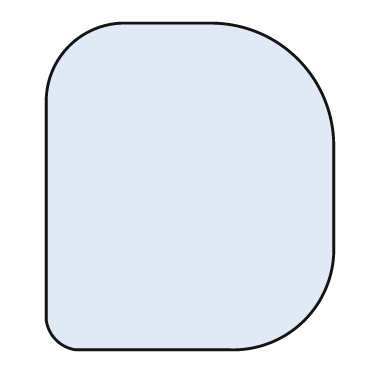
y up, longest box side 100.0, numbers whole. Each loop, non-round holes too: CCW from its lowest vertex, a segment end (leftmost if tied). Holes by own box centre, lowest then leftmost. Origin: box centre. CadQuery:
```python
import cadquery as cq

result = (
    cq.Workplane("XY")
    .moveTo(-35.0, -50.0)
    .lineTo(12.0, -50.0)
    .threePointArc((35.0, -41.0), (44.0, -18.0))
    .lineTo(44.0, 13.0)
    .threePointArc((33.0, 39.0), (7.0, 50.0))
    .lineTo(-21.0, 50.0)
    .threePointArc((-37.0, 43.0), (-44.0, 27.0))
    .lineTo(-44.0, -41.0)
    .threePointArc((-41.0, -47.0), (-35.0, -50.0))
    .close()
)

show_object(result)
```